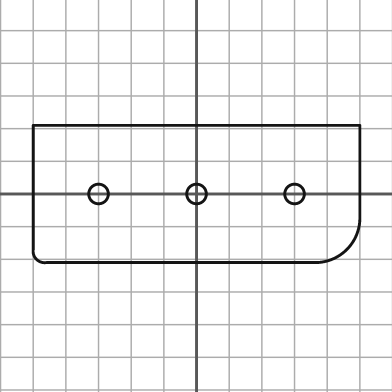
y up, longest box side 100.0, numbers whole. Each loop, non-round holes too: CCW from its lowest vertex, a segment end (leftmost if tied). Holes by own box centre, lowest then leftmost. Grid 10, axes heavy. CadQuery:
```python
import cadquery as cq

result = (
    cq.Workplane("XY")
    .moveTo(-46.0, -21.0)
    .lineTo(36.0, -21.0)
    .threePointArc((46.0, -17.0), (50.0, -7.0))
    .lineTo(50.0, 21.0)
    .lineTo(-50.0, 21.0)
    .lineTo(-50.0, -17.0)
    .threePointArc((-49.0, -20.0), (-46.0, -21.0))
    .close()
    .moveTo(-30.0, 0.0)
    .circle(3.0)
    .moveTo(0.0, 0.0)
    .circle(3.0)
    .moveTo(30.0, 0.0)
    .circle(3.0)
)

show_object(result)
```